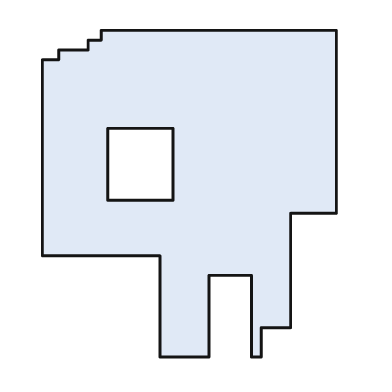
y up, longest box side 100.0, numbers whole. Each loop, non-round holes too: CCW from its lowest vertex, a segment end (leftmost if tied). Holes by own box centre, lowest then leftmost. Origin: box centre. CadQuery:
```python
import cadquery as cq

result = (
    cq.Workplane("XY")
    .moveTo(-9.0, -50.0)
    .lineTo(6.0, -50.0)
    .lineTo(6.0, -25.0)
    .lineTo(19.0, -25.0)
    .lineTo(19.0, -50.0)
    .lineTo(22.0, -50.0)
    .lineTo(22.0, -41.0)
    .lineTo(31.0, -41.0)
    .lineTo(31.0, -6.0)
    .lineTo(45.0, -6.0)
    .lineTo(45.0, 50.0)
    .lineTo(-27.0, 50.0)
    .lineTo(-27.0, 47.0)
    .lineTo(-31.0, 47.0)
    .lineTo(-31.0, 44.0)
    .lineTo(-40.0, 44.0)
    .lineTo(-40.0, 41.0)
    .lineTo(-45.0, 41.0)
    .lineTo(-45.0, -19.0)
    .lineTo(-9.0, -19.0)
    .close()
    .moveTo(-25.0, -2.0)
    .lineTo(-5.0, -2.0)
    .lineTo(-5.0, 20.0)
    .lineTo(-25.0, 20.0)
    .close()
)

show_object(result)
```